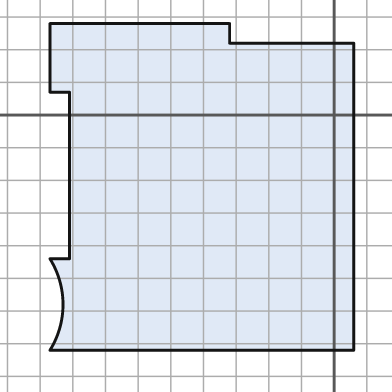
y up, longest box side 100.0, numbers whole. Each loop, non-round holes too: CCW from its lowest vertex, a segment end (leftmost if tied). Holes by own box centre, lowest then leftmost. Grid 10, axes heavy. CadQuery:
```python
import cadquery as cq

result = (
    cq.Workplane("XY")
    .moveTo(-87.0, -72.0)
    .lineTo(6.0, -72.0)
    .lineTo(6.0, 22.0)
    .lineTo(-32.0, 22.0)
    .lineTo(-32.0, 28.0)
    .lineTo(-87.0, 28.0)
    .lineTo(-87.0, 7.0)
    .lineTo(-81.0, 7.0)
    .lineTo(-81.0, -44.0)
    .lineTo(-87.0, -44.0)
    .threePointArc((-83.0, -58.0), (-87.0, -72.0))
    .close()
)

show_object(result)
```